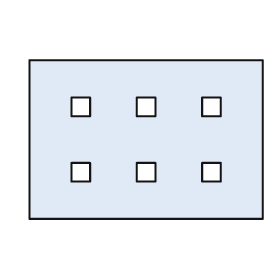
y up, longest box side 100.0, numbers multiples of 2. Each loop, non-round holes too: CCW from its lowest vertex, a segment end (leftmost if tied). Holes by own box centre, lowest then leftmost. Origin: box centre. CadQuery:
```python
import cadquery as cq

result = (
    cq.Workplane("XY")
    .moveTo(-50.0, -34.0)
    .lineTo(50.0, -34.0)
    .lineTo(50.0, 34.0)
    .lineTo(-50.0, 34.0)
    .close()
    .moveTo(-32.0, -18.0)
    .lineTo(-24.0, -18.0)
    .lineTo(-24.0, -10.0)
    .lineTo(-32.0, -10.0)
    .close()
    .moveTo(-4.0, -18.0)
    .lineTo(4.0, -18.0)
    .lineTo(4.0, -10.0)
    .lineTo(-4.0, -10.0)
    .close()
    .moveTo(24.0, -18.0)
    .lineTo(32.0, -18.0)
    .lineTo(32.0, -10.0)
    .lineTo(24.0, -10.0)
    .close()
    .moveTo(-32.0, 10.0)
    .lineTo(-24.0, 10.0)
    .lineTo(-24.0, 18.0)
    .lineTo(-32.0, 18.0)
    .close()
    .moveTo(-4.0, 10.0)
    .lineTo(4.0, 10.0)
    .lineTo(4.0, 18.0)
    .lineTo(-4.0, 18.0)
    .close()
    .moveTo(24.0, 10.0)
    .lineTo(32.0, 10.0)
    .lineTo(32.0, 18.0)
    .lineTo(24.0, 18.0)
    .close()
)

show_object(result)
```